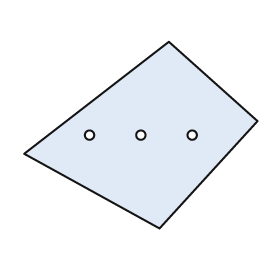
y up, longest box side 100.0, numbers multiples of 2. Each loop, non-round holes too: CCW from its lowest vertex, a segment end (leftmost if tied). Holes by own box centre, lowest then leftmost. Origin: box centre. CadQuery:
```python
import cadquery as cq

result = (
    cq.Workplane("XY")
    .moveTo(8.0, -40.0)
    .lineTo(50.0, 6.0)
    .lineTo(12.0, 40.0)
    .lineTo(-50.0, -8.0)
    .close()
    .moveTo(-22.0, 0.0)
    .circle(2.0)
    .moveTo(0.0, 0.0)
    .circle(2.0)
    .moveTo(22.0, 0.0)
    .circle(2.0)
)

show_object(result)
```